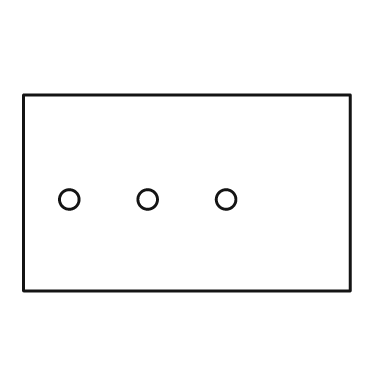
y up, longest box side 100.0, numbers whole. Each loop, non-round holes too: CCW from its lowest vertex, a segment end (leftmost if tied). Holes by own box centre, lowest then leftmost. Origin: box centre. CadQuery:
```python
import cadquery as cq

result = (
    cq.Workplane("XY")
    .moveTo(-50.0, -30.0)
    .lineTo(50.0, -30.0)
    .lineTo(50.0, 30.0)
    .lineTo(-50.0, 30.0)
    .close()
    .moveTo(-36.0, -2.0)
    .circle(3.0)
    .moveTo(-12.0, -2.0)
    .circle(3.0)
    .moveTo(12.0, -2.0)
    .circle(3.0)
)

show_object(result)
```